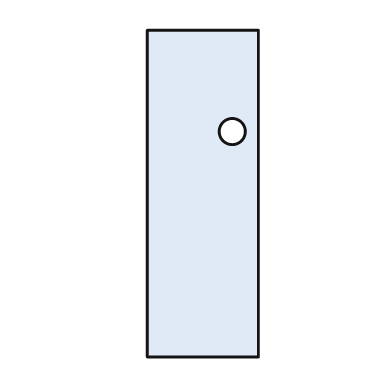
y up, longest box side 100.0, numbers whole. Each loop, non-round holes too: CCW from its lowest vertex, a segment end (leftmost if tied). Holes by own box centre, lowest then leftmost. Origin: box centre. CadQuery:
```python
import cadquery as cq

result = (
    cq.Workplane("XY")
    .moveTo(-17.0, -50.0)
    .lineTo(17.0, -50.0)
    .lineTo(17.0, 50.0)
    .lineTo(-17.0, 50.0)
    .close()
    .moveTo(9.0, 19.0)
    .circle(4.0)
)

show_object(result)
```